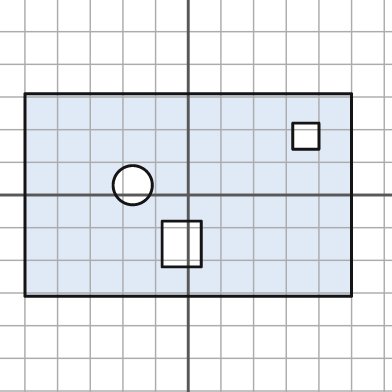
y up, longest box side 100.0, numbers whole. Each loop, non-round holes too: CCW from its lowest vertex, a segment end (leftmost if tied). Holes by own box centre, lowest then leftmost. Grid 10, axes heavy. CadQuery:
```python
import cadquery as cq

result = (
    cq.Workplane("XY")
    .moveTo(-50.0, -31.0)
    .lineTo(50.0, -31.0)
    .lineTo(50.0, 31.0)
    .lineTo(-50.0, 31.0)
    .close()
    .moveTo(-8.0, -22.0)
    .lineTo(4.0, -22.0)
    .lineTo(4.0, -8.0)
    .lineTo(-8.0, -8.0)
    .close()
    .moveTo(-17.0, 3.0)
    .circle(6.0)
    .moveTo(32.0, 14.0)
    .lineTo(40.0, 14.0)
    .lineTo(40.0, 22.0)
    .lineTo(32.0, 22.0)
    .close()
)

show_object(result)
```